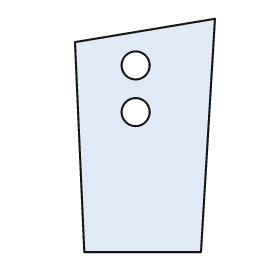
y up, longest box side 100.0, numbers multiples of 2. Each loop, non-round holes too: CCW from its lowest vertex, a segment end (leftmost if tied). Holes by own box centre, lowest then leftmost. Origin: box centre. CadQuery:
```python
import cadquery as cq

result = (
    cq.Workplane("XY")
    .moveTo(-26.0, -50.0)
    .lineTo(24.0, -50.0)
    .lineTo(30.0, 50.0)
    .lineTo(-30.0, 40.0)
    .close()
    .moveTo(-4.0, 10.0)
    .circle(6.0)
    .moveTo(-4.0, 30.0)
    .circle(6.0)
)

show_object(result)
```